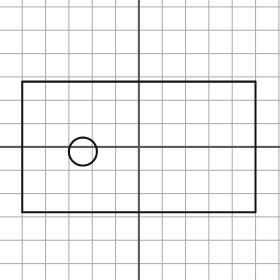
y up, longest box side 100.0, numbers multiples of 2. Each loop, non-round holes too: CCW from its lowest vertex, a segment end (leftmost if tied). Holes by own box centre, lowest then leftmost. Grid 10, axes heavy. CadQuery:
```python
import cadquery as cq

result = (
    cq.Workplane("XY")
    .moveTo(-50.0, -28.0)
    .lineTo(50.0, -28.0)
    .lineTo(50.0, 28.0)
    .lineTo(-50.0, 28.0)
    .close()
    .moveTo(-24.0, -2.0)
    .circle(6.0)
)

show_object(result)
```